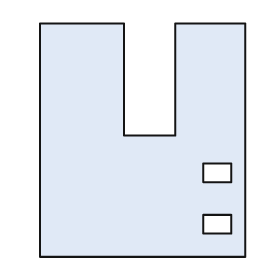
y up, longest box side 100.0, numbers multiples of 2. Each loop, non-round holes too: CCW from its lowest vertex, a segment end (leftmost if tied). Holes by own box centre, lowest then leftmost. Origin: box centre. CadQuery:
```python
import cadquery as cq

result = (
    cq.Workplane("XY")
    .moveTo(-44.0, -50.0)
    .lineTo(44.0, -50.0)
    .lineTo(44.0, 50.0)
    .lineTo(14.0, 50.0)
    .lineTo(14.0, 2.0)
    .lineTo(-8.0, 2.0)
    .lineTo(-8.0, 50.0)
    .lineTo(-44.0, 50.0)
    .close()
    .moveTo(26.0, -40.0)
    .lineTo(38.0, -40.0)
    .lineTo(38.0, -32.0)
    .lineTo(26.0, -32.0)
    .close()
    .moveTo(26.0, -18.0)
    .lineTo(38.0, -18.0)
    .lineTo(38.0, -10.0)
    .lineTo(26.0, -10.0)
    .close()
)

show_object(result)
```